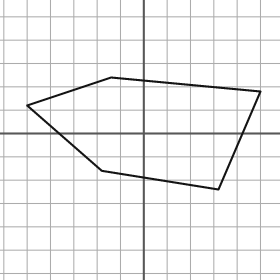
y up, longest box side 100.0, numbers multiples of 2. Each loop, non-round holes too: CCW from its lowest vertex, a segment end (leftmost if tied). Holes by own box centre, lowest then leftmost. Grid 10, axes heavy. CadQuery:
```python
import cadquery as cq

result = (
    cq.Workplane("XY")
    .moveTo(32.0, -24.0)
    .lineTo(50.0, 18.0)
    .lineTo(-14.0, 24.0)
    .lineTo(-50.0, 12.0)
    .lineTo(-18.0, -16.0)
    .close()
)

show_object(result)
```